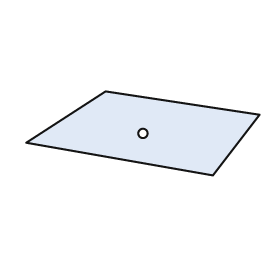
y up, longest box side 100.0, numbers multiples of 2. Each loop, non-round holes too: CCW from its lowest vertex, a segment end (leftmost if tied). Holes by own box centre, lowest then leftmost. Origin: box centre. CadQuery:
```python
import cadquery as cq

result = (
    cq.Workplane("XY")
    .moveTo(30.0, -18.0)
    .lineTo(50.0, 8.0)
    .lineTo(-16.0, 18.0)
    .lineTo(-50.0, -4.0)
    .close()
    .moveTo(0.0, 0.0)
    .circle(2.0)
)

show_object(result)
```